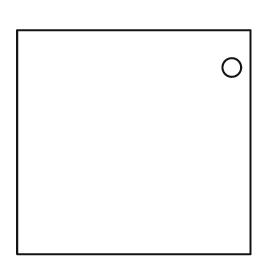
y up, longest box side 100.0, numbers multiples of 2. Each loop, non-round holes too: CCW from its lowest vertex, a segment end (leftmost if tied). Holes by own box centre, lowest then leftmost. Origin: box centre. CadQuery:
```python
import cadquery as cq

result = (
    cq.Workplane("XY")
    .moveTo(-50.0, -48.0)
    .lineTo(50.0, -48.0)
    .lineTo(50.0, 48.0)
    .lineTo(-50.0, 48.0)
    .close()
    .moveTo(42.0, 32.0)
    .circle(4.0)
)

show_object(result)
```